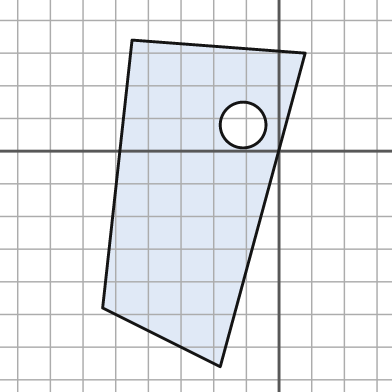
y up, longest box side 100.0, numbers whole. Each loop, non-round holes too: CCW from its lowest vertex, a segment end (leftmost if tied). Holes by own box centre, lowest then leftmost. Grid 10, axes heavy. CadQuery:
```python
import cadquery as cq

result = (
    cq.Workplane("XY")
    .moveTo(-18.0, -66.0)
    .lineTo(8.0, 30.0)
    .lineTo(-45.0, 34.0)
    .lineTo(-54.0, -48.0)
    .close()
    .moveTo(-11.0, 8.0)
    .circle(7.0)
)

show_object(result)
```